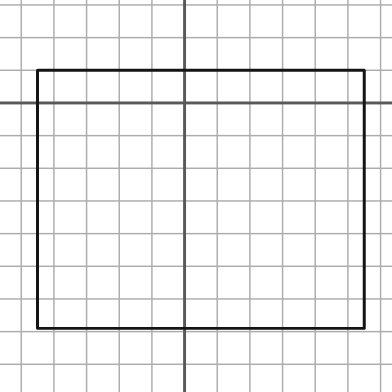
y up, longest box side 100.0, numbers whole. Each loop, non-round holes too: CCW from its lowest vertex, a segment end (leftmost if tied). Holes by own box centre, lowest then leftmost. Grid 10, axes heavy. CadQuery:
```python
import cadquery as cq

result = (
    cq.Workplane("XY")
    .moveTo(-45.0, -69.0)
    .lineTo(55.0, -69.0)
    .lineTo(55.0, 10.0)
    .lineTo(-45.0, 10.0)
    .close()
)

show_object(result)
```